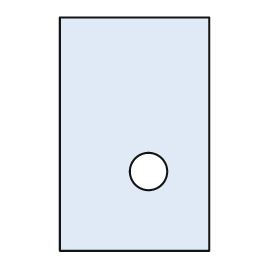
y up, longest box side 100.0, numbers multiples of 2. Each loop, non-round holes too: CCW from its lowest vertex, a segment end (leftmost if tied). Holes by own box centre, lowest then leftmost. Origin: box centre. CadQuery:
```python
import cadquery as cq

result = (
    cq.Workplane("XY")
    .moveTo(-32.0, -50.0)
    .lineTo(32.0, -50.0)
    .lineTo(32.0, 50.0)
    .lineTo(-32.0, 50.0)
    .close()
    .moveTo(6.0, -16.0)
    .circle(8.0)
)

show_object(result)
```